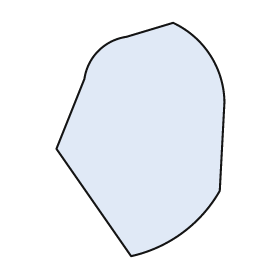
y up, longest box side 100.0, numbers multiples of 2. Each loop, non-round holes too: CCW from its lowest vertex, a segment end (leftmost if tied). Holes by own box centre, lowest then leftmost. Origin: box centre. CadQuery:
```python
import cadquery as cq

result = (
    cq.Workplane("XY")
    .moveTo(-4.0, -50.0)
    .threePointArc((18.0, -40.0), (34.0, -22.0))
    .lineTo(36.0, 16.0)
    .threePointArc((30.0, 36.0), (14.0, 50.0))
    .lineTo(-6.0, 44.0)
    .threePointArc((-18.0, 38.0), (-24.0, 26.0))
    .lineTo(-36.0, -4.0)
    .close()
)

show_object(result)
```